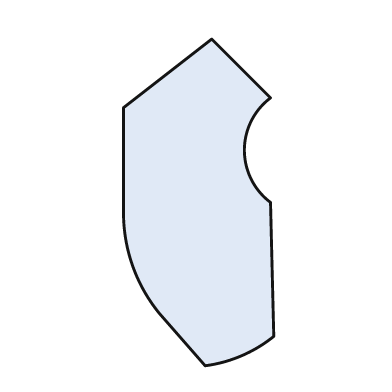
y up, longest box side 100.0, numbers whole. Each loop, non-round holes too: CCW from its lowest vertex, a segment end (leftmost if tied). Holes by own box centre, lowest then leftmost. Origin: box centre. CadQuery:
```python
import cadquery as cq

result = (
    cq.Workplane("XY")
    .moveTo(2.0, -50.0)
    .threePointArc((13.0, -47.0), (23.0, -41.0))
    .lineTo(22.0, 0.0)
    .threePointArc((14.0, 16.0), (22.0, 32.0))
    .lineTo(4.0, 50.0)
    .lineTo(-23.0, 29.0)
    .lineTo(-23.0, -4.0)
    .threePointArc((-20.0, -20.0), (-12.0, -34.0))
    .close()
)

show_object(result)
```